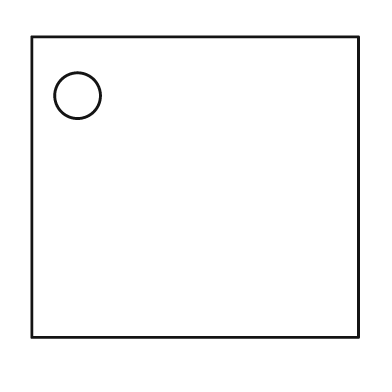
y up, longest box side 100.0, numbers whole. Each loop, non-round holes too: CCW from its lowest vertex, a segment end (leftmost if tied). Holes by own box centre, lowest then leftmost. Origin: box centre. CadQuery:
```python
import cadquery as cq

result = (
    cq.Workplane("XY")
    .moveTo(-50.0, -46.0)
    .lineTo(50.0, -46.0)
    .lineTo(50.0, 46.0)
    .lineTo(-50.0, 46.0)
    .close()
    .moveTo(-36.0, 28.0)
    .circle(7.0)
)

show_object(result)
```